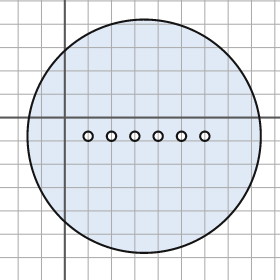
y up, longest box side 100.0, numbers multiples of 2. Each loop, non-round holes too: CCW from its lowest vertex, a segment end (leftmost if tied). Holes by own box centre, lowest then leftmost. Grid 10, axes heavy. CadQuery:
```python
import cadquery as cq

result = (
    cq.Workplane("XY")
    .moveTo(34.0, -8.0)
    .circle(50.0)
    .moveTo(10.0, -8.0)
    .circle(2.0)
    .moveTo(20.0, -8.0)
    .circle(2.0)
    .moveTo(30.0, -8.0)
    .circle(2.0)
    .moveTo(40.0, -8.0)
    .circle(2.0)
    .moveTo(50.0, -8.0)
    .circle(2.0)
    .moveTo(60.0, -8.0)
    .circle(2.0)
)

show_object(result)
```